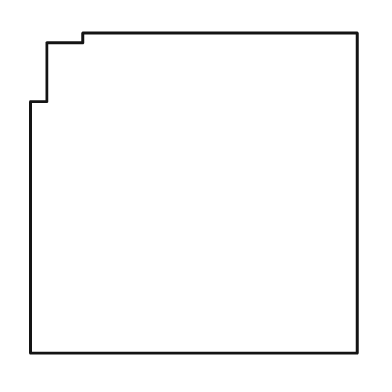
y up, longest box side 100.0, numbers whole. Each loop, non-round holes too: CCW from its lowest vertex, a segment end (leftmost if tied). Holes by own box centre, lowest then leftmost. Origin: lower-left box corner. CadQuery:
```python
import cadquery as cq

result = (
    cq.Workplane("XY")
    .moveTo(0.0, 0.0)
    .lineTo(100.0, 0.0)
    .lineTo(100.0, 98.0)
    .lineTo(16.0, 98.0)
    .lineTo(16.0, 95.0)
    .lineTo(5.0, 95.0)
    .lineTo(5.0, 77.0)
    .lineTo(0.0, 77.0)
    .close()
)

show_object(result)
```